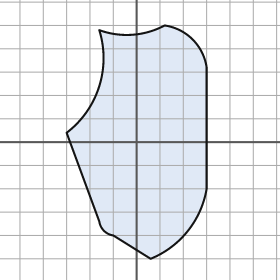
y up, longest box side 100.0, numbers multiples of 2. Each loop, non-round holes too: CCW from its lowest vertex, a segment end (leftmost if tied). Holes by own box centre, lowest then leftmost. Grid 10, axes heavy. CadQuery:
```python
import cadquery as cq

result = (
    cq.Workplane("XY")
    .moveTo(6.0, -50.0)
    .threePointArc((22.0, -38.0), (30.0, -20.0))
    .lineTo(30.0, 32.0)
    .threePointArc((24.0, 44.0), (12.0, 50.0))
    .threePointArc((-2.0, 46.0), (-16.0, 48.0))
    .threePointArc((-16.0, 24.0), (-30.0, 4.0))
    .lineTo(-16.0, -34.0)
    .threePointArc((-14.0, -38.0), (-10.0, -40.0))
    .close()
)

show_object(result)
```